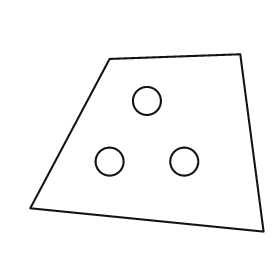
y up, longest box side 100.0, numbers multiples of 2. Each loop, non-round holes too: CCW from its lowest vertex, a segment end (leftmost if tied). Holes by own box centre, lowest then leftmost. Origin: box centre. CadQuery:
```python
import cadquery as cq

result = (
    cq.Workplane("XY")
    .moveTo(50.0, -38.0)
    .lineTo(40.0, 38.0)
    .lineTo(-16.0, 36.0)
    .lineTo(-50.0, -28.0)
    .close()
    .moveTo(-16.0, -8.0)
    .circle(6.0)
    .moveTo(16.0, -8.0)
    .circle(6.0)
    .moveTo(0.0, 18.0)
    .circle(6.0)
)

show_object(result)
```